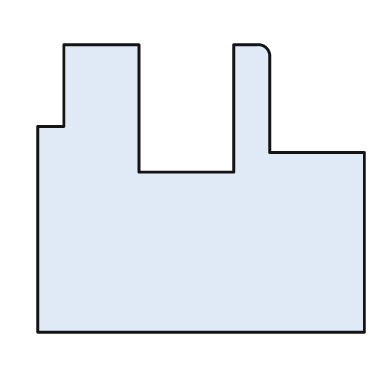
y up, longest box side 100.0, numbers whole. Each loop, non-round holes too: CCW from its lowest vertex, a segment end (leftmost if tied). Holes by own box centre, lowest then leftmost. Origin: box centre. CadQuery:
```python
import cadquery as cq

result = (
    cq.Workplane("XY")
    .moveTo(-50.0, -44.0)
    .lineTo(50.0, -44.0)
    .lineTo(50.0, 11.0)
    .lineTo(21.0, 11.0)
    .lineTo(21.0, 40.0)
    .threePointArc((20.0, 43.0), (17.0, 44.0))
    .lineTo(10.0, 44.0)
    .lineTo(10.0, 5.0)
    .lineTo(-19.0, 5.0)
    .lineTo(-19.0, 44.0)
    .lineTo(-42.0, 44.0)
    .lineTo(-42.0, 19.0)
    .lineTo(-50.0, 19.0)
    .close()
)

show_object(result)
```